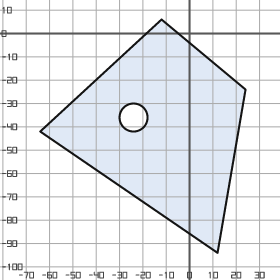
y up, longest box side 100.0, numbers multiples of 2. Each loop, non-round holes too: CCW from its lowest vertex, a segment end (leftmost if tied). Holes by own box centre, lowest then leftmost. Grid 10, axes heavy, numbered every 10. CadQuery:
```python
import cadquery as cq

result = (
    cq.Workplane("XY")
    .moveTo(12.0, -94.0)
    .lineTo(24.0, -24.0)
    .lineTo(-12.0, 6.0)
    .lineTo(-64.0, -42.0)
    .close()
    .moveTo(-24.0, -36.0)
    .circle(6.0)
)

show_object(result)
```